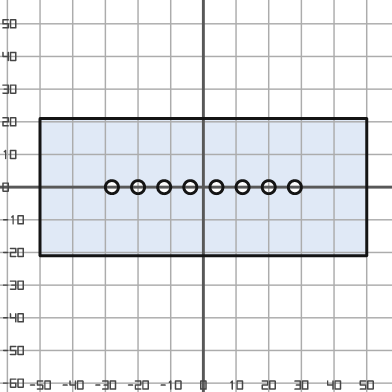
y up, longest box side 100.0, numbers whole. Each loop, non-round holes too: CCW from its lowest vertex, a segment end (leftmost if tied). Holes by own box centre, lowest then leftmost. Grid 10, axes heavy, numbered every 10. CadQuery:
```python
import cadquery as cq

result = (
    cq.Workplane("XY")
    .moveTo(-50.0, -21.0)
    .lineTo(50.0, -21.0)
    .lineTo(50.0, 21.0)
    .lineTo(-50.0, 21.0)
    .close()
    .moveTo(-28.0, 0.0)
    .circle(2.0)
    .moveTo(-20.0, 0.0)
    .circle(2.0)
    .moveTo(-12.0, 0.0)
    .circle(2.0)
    .moveTo(-4.0, 0.0)
    .circle(2.0)
    .moveTo(4.0, 0.0)
    .circle(2.0)
    .moveTo(12.0, 0.0)
    .circle(2.0)
    .moveTo(20.0, 0.0)
    .circle(2.0)
    .moveTo(28.0, 0.0)
    .circle(2.0)
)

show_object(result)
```